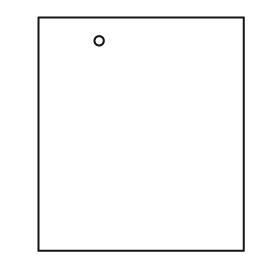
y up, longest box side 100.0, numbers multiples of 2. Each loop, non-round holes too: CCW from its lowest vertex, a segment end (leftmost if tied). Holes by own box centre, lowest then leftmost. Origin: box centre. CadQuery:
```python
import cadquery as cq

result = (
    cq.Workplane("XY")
    .moveTo(-44.0, -50.0)
    .lineTo(44.0, -50.0)
    .lineTo(44.0, 50.0)
    .lineTo(-44.0, 50.0)
    .close()
    .moveTo(-18.0, 40.0)
    .circle(2.0)
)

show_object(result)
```